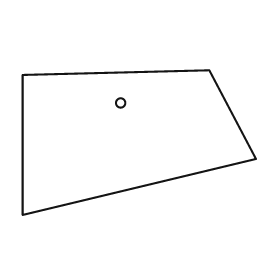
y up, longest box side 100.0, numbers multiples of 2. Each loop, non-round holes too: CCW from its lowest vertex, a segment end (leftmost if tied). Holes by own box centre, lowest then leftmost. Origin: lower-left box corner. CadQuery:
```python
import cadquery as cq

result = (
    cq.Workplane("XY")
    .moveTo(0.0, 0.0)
    .lineTo(100.0, 24.0)
    .lineTo(80.0, 62.0)
    .lineTo(0.0, 60.0)
    .close()
    .moveTo(42.0, 48.0)
    .circle(2.0)
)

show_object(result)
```